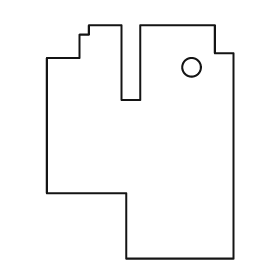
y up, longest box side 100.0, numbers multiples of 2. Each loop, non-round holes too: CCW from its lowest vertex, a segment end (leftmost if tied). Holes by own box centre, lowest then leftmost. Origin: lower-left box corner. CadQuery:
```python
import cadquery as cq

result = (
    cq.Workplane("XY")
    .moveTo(34.0, 0.0)
    .lineTo(80.0, 0.0)
    .lineTo(80.0, 88.0)
    .lineTo(72.0, 88.0)
    .lineTo(72.0, 100.0)
    .lineTo(40.0, 100.0)
    .lineTo(40.0, 68.0)
    .lineTo(32.0, 68.0)
    .lineTo(32.0, 100.0)
    .lineTo(18.0, 100.0)
    .lineTo(18.0, 96.0)
    .lineTo(14.0, 96.0)
    .lineTo(14.0, 86.0)
    .lineTo(0.0, 86.0)
    .lineTo(0.0, 28.0)
    .lineTo(34.0, 28.0)
    .close()
    .moveTo(62.0, 82.0)
    .circle(4.0)
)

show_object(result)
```